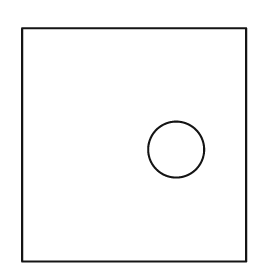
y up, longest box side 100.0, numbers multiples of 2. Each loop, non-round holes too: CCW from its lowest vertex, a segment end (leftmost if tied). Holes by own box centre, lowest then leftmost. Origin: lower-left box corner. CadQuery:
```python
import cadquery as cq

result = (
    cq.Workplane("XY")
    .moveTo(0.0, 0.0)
    .lineTo(96.0, 0.0)
    .lineTo(96.0, 100.0)
    .lineTo(0.0, 100.0)
    .close()
    .moveTo(66.0, 48.0)
    .circle(12.0)
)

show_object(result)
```